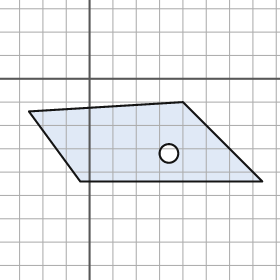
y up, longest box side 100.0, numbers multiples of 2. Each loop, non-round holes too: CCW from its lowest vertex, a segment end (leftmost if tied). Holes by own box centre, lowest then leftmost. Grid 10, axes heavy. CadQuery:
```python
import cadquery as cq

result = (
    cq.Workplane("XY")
    .moveTo(-4.0, -44.0)
    .lineTo(74.0, -44.0)
    .lineTo(40.0, -10.0)
    .lineTo(-26.0, -14.0)
    .close()
    .moveTo(34.0, -32.0)
    .circle(4.0)
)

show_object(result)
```